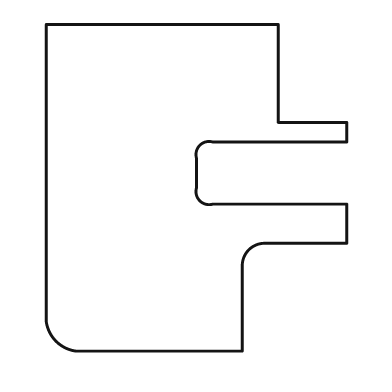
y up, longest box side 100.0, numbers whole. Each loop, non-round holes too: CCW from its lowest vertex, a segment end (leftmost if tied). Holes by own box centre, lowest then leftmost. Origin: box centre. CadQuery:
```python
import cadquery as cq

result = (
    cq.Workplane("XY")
    .moveTo(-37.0, -50.0)
    .lineTo(14.0, -50.0)
    .lineTo(14.0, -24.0)
    .threePointArc((16.0, -19.0), (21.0, -17.0))
    .lineTo(46.0, -17.0)
    .lineTo(46.0, -5.0)
    .lineTo(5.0, -5.0)
    .threePointArc((1.0, -4.0), (0.0, 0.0))
    .lineTo(0.0, 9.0)
    .threePointArc((1.0, 13.0), (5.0, 14.0))
    .lineTo(46.0, 14.0)
    .lineTo(46.0, 20.0)
    .lineTo(25.0, 20.0)
    .lineTo(25.0, 50.0)
    .lineTo(-46.0, 50.0)
    .lineTo(-46.0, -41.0)
    .threePointArc((-43.0, -47.0), (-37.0, -50.0))
    .close()
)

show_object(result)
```